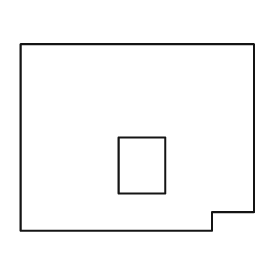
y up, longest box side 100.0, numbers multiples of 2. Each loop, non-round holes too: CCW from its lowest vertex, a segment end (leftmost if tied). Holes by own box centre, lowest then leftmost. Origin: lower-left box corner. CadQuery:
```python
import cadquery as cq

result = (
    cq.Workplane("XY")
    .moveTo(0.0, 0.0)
    .lineTo(82.0, 0.0)
    .lineTo(82.0, 8.0)
    .lineTo(100.0, 8.0)
    .lineTo(100.0, 80.0)
    .lineTo(0.0, 80.0)
    .close()
    .moveTo(42.0, 16.0)
    .lineTo(62.0, 16.0)
    .lineTo(62.0, 40.0)
    .lineTo(42.0, 40.0)
    .close()
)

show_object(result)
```